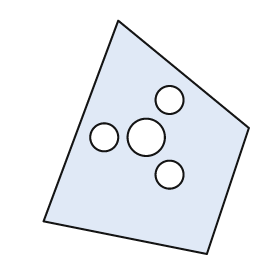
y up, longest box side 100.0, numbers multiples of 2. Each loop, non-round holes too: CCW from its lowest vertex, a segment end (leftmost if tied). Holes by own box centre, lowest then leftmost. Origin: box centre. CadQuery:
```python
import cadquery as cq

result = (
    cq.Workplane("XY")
    .moveTo(26.0, -50.0)
    .lineTo(44.0, 4.0)
    .lineTo(-12.0, 50.0)
    .lineTo(-44.0, -36.0)
    .close()
    .moveTo(10.0, -16.0)
    .circle(6.0)
    .moveTo(-18.0, 0.0)
    .circle(6.0)
    .moveTo(0.0, 0.0)
    .circle(8.0)
    .moveTo(10.0, 16.0)
    .circle(6.0)
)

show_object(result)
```